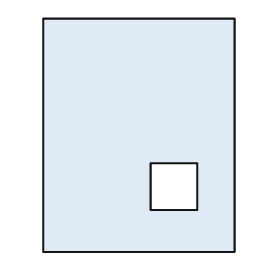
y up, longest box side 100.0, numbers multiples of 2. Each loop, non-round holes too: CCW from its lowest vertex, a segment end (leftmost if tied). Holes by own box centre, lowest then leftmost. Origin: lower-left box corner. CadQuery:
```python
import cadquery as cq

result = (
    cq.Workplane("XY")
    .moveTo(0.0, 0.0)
    .lineTo(82.0, 0.0)
    .lineTo(82.0, 100.0)
    .lineTo(0.0, 100.0)
    .close()
    .moveTo(46.0, 18.0)
    .lineTo(66.0, 18.0)
    .lineTo(66.0, 38.0)
    .lineTo(46.0, 38.0)
    .close()
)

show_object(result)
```